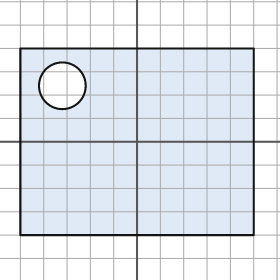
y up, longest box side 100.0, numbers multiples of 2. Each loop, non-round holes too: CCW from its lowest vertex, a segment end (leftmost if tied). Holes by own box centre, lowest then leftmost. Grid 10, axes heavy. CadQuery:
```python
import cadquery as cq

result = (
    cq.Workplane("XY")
    .moveTo(-50.0, -40.0)
    .lineTo(50.0, -40.0)
    .lineTo(50.0, 40.0)
    .lineTo(-50.0, 40.0)
    .close()
    .moveTo(-32.0, 24.0)
    .circle(10.0)
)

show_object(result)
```